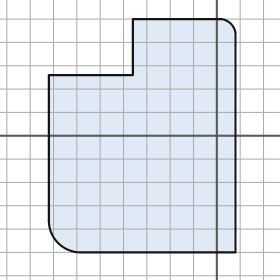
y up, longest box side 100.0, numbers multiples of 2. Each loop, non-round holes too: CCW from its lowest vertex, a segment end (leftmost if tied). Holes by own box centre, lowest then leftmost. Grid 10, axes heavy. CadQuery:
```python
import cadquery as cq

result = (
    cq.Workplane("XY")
    .moveTo(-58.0, -50.0)
    .lineTo(8.0, -50.0)
    .lineTo(8.0, 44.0)
    .threePointArc((6.0, 48.0), (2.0, 50.0))
    .lineTo(-36.0, 50.0)
    .lineTo(-36.0, 26.0)
    .lineTo(-72.0, 26.0)
    .lineTo(-72.0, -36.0)
    .threePointArc((-68.0, -46.0), (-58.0, -50.0))
    .close()
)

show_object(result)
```